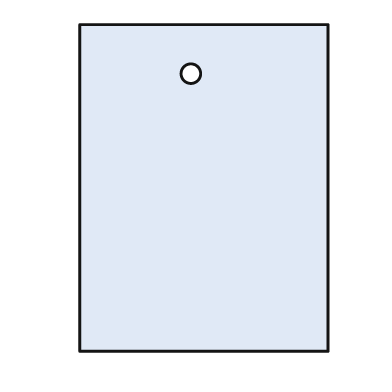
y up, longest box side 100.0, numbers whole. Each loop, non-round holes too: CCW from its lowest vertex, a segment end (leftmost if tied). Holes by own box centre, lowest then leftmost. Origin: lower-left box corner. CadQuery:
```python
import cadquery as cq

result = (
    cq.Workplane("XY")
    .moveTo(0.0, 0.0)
    .lineTo(76.0, 0.0)
    .lineTo(76.0, 100.0)
    .lineTo(0.0, 100.0)
    .close()
    .moveTo(34.0, 85.0)
    .circle(3.0)
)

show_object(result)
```